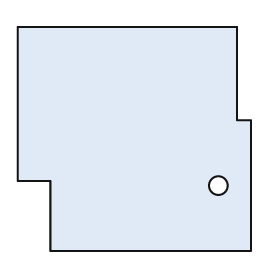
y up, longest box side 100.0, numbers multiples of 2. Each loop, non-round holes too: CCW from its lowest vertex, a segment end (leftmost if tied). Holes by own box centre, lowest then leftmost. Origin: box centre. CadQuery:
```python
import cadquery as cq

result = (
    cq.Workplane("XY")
    .moveTo(-36.0, -48.0)
    .lineTo(50.0, -48.0)
    .lineTo(50.0, 8.0)
    .lineTo(44.0, 8.0)
    .lineTo(44.0, 48.0)
    .lineTo(-50.0, 48.0)
    .lineTo(-50.0, -18.0)
    .lineTo(-36.0, -18.0)
    .close()
    .moveTo(36.0, -20.0)
    .circle(4.0)
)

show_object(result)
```